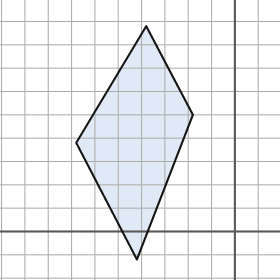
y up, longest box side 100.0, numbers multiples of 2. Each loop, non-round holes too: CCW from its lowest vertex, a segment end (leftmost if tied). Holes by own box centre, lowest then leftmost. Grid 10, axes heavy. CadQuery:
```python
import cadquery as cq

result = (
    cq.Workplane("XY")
    .moveTo(-42.0, -12.0)
    .lineTo(-18.0, 50.0)
    .lineTo(-38.0, 88.0)
    .lineTo(-68.0, 38.0)
    .close()
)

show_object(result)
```